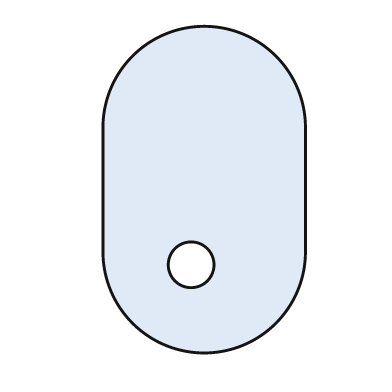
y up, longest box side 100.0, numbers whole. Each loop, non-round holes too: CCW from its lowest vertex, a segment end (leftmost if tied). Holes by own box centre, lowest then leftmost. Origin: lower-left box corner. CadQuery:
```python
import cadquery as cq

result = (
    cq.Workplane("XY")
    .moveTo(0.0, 31.0)
    .threePointArc((31.0, 0.0), (62.0, 31.0))
    .lineTo(62.0, 69.0)
    .threePointArc((31.0, 100.0), (0.0, 69.0))
    .close()
    .moveTo(27.0, 27.0)
    .circle(7.0)
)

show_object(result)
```